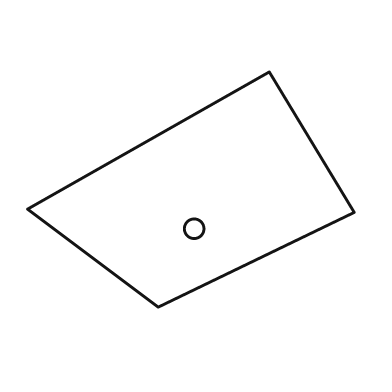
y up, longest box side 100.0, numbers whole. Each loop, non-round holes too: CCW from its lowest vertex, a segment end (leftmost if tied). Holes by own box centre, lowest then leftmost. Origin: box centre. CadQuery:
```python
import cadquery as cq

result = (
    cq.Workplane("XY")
    .moveTo(-10.0, -36.0)
    .lineTo(50.0, -7.0)
    .lineTo(24.0, 36.0)
    .lineTo(-50.0, -6.0)
    .close()
    .moveTo(1.0, -12.0)
    .circle(3.0)
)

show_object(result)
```